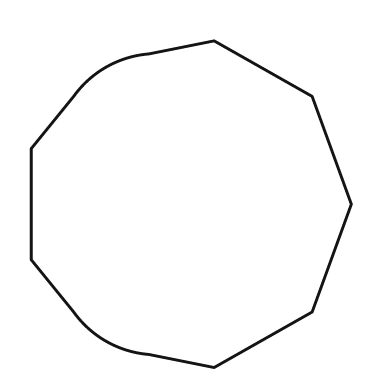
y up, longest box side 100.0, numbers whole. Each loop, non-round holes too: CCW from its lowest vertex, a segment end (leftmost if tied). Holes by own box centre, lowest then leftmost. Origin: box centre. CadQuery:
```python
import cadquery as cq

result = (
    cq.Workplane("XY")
    .moveTo(7.0, -50.0)
    .lineTo(37.0, -33.0)
    .lineTo(49.0, 0.0)
    .lineTo(37.0, 33.0)
    .lineTo(7.0, 50.0)
    .lineTo(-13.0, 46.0)
    .threePointArc((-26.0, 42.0), (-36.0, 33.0))
    .lineTo(-49.0, 17.0)
    .lineTo(-49.0, -17.0)
    .lineTo(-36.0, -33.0)
    .threePointArc((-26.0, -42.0), (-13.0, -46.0))
    .close()
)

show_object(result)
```